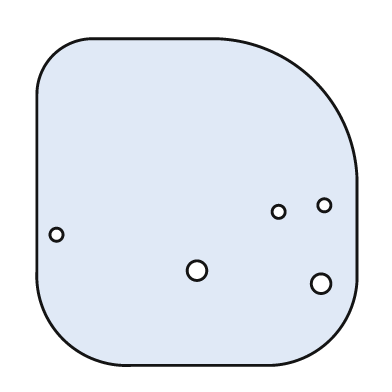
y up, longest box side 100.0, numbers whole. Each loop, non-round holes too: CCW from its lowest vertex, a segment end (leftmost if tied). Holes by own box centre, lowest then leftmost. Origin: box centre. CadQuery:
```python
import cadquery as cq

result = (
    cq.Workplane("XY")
    .moveTo(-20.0, -50.0)
    .lineTo(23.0, -50.0)
    .threePointArc((41.0, -42.0), (49.0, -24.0))
    .lineTo(49.0, 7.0)
    .threePointArc((36.0, 37.0), (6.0, 50.0))
    .lineTo(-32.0, 50.0)
    .threePointArc((-44.0, 45.0), (-49.0, 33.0))
    .lineTo(-49.0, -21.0)
    .threePointArc((-41.0, -42.0), (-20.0, -50.0))
    .close()
    .moveTo(38.0, -25.0)
    .circle(3.0)
    .moveTo(0.0, -21.0)
    .circle(3.0)
    .moveTo(-43.0, -10.0)
    .circle(2.0)
    .moveTo(25.0, -3.0)
    .circle(2.0)
    .moveTo(39.0, -1.0)
    .circle(2.0)
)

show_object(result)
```